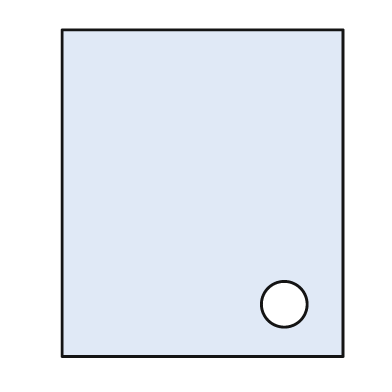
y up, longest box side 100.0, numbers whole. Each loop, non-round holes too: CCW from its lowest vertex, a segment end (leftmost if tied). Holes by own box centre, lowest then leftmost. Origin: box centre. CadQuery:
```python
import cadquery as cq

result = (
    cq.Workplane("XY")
    .moveTo(-43.0, -50.0)
    .lineTo(43.0, -50.0)
    .lineTo(43.0, 50.0)
    .lineTo(-43.0, 50.0)
    .close()
    .moveTo(25.0, -34.0)
    .circle(7.0)
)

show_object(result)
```